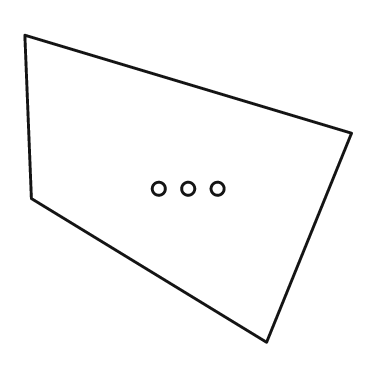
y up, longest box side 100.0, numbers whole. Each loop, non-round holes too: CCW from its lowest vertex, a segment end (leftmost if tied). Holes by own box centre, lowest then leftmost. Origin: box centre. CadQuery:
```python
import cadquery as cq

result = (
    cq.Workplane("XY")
    .moveTo(24.0, -47.0)
    .lineTo(50.0, 17.0)
    .lineTo(-50.0, 47.0)
    .lineTo(-48.0, -3.0)
    .close()
    .moveTo(-9.0, 0.0)
    .circle(2.0)
    .moveTo(0.0, 0.0)
    .circle(2.0)
    .moveTo(9.0, 0.0)
    .circle(2.0)
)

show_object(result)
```